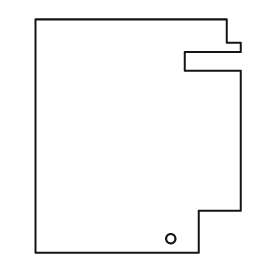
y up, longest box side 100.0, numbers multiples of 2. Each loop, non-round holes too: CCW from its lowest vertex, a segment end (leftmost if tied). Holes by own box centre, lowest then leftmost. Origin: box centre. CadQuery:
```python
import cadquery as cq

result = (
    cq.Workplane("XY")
    .moveTo(-44.0, -50.0)
    .lineTo(26.0, -50.0)
    .lineTo(26.0, -32.0)
    .lineTo(44.0, -32.0)
    .lineTo(44.0, 28.0)
    .lineTo(20.0, 28.0)
    .lineTo(20.0, 36.0)
    .lineTo(44.0, 36.0)
    .lineTo(44.0, 40.0)
    .lineTo(38.0, 40.0)
    .lineTo(38.0, 50.0)
    .lineTo(-44.0, 50.0)
    .close()
    .moveTo(14.0, -44.0)
    .circle(2.0)
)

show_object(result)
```